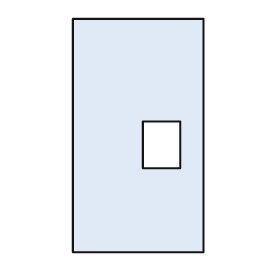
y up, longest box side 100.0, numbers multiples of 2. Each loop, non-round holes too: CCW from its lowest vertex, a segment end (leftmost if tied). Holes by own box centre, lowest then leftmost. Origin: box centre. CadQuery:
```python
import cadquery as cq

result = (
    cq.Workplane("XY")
    .moveTo(-28.0, -50.0)
    .lineTo(28.0, -50.0)
    .lineTo(28.0, 50.0)
    .lineTo(-28.0, 50.0)
    .close()
    .moveTo(2.0, -14.0)
    .lineTo(18.0, -14.0)
    .lineTo(18.0, 6.0)
    .lineTo(2.0, 6.0)
    .close()
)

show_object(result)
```